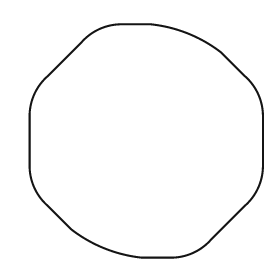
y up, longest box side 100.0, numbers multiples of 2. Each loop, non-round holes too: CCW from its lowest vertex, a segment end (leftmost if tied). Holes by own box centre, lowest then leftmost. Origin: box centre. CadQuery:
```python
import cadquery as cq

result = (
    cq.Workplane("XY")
    .moveTo(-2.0, -50.0)
    .lineTo(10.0, -50.0)
    .threePointArc((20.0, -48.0), (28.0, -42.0))
    .lineTo(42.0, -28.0)
    .threePointArc((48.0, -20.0), (50.0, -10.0))
    .lineTo(50.0, 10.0)
    .threePointArc((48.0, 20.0), (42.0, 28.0))
    .lineTo(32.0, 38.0)
    .threePointArc((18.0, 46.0), (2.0, 50.0))
    .lineTo(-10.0, 50.0)
    .threePointArc((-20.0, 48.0), (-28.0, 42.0))
    .lineTo(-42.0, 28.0)
    .threePointArc((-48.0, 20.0), (-50.0, 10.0))
    .lineTo(-50.0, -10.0)
    .threePointArc((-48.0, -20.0), (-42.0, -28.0))
    .lineTo(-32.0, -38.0)
    .threePointArc((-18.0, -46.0), (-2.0, -50.0))
    .close()
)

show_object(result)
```